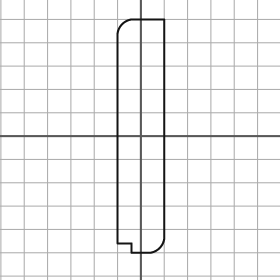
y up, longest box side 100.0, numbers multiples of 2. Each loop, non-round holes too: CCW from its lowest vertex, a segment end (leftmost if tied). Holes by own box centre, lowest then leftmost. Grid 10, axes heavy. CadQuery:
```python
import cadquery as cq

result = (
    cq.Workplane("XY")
    .moveTo(-4.0, -50.0)
    .lineTo(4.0, -50.0)
    .threePointArc((8.0, -48.0), (10.0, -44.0))
    .lineTo(10.0, 50.0)
    .lineTo(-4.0, 50.0)
    .threePointArc((-8.0, 48.0), (-10.0, 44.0))
    .lineTo(-10.0, -46.0)
    .lineTo(-4.0, -46.0)
    .close()
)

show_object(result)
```